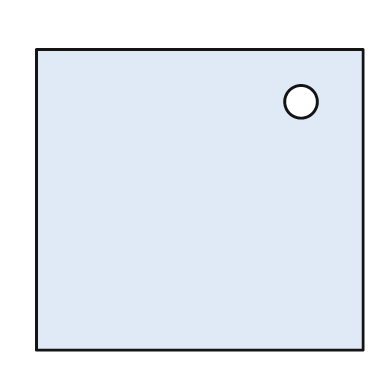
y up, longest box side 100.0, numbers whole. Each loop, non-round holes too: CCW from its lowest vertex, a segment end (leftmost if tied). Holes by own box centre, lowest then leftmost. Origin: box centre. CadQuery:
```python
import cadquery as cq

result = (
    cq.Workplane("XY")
    .moveTo(-50.0, -46.0)
    .lineTo(50.0, -46.0)
    .lineTo(50.0, 46.0)
    .lineTo(-50.0, 46.0)
    .close()
    .moveTo(31.0, 30.0)
    .circle(5.0)
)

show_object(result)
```